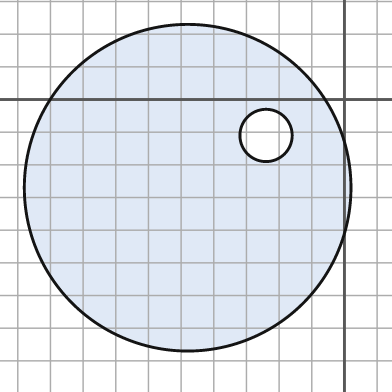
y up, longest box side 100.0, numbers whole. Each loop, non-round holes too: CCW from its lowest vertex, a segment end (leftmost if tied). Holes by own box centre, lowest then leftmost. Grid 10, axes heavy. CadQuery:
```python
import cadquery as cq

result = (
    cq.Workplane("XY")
    .moveTo(-48.0, -27.0)
    .circle(50.0)
    .moveTo(-24.0, -11.0)
    .circle(8.0)
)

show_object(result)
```